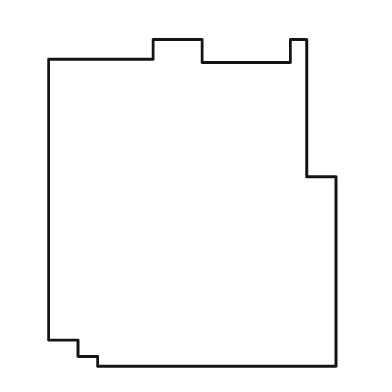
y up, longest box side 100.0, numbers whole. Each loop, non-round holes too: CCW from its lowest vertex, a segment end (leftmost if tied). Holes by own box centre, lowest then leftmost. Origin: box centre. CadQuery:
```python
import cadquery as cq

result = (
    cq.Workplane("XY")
    .moveTo(-29.0, -50.0)
    .lineTo(44.0, -50.0)
    .lineTo(44.0, 8.0)
    .lineTo(35.0, 8.0)
    .lineTo(35.0, 50.0)
    .lineTo(30.0, 50.0)
    .lineTo(30.0, 43.0)
    .lineTo(3.0, 43.0)
    .lineTo(3.0, 50.0)
    .lineTo(-12.0, 50.0)
    .lineTo(-12.0, 44.0)
    .lineTo(-44.0, 44.0)
    .lineTo(-44.0, -42.0)
    .lineTo(-35.0, -42.0)
    .lineTo(-35.0, -47.0)
    .lineTo(-29.0, -47.0)
    .close()
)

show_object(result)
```